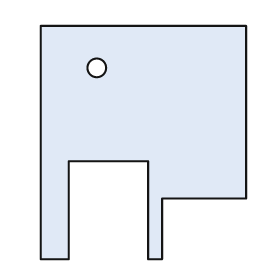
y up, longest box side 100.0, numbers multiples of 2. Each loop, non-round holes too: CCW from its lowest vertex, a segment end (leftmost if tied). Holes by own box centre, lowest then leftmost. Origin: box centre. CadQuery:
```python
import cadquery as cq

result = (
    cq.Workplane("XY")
    .moveTo(-44.0, -50.0)
    .lineTo(-32.0, -50.0)
    .lineTo(-32.0, -8.0)
    .lineTo(2.0, -8.0)
    .lineTo(2.0, -50.0)
    .lineTo(8.0, -50.0)
    .lineTo(8.0, -24.0)
    .lineTo(44.0, -24.0)
    .lineTo(44.0, 50.0)
    .lineTo(-44.0, 50.0)
    .close()
    .moveTo(-20.0, 32.0)
    .circle(4.0)
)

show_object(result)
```